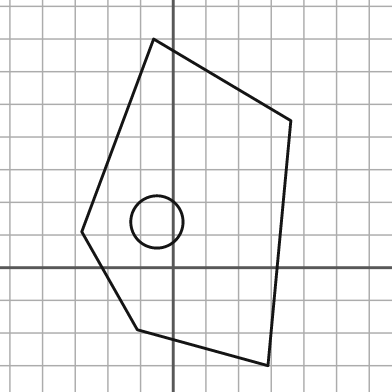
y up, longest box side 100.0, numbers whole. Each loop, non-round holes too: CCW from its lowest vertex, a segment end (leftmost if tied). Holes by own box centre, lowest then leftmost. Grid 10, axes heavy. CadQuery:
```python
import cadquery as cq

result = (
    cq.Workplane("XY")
    .moveTo(29.0, -30.0)
    .lineTo(36.0, 45.0)
    .lineTo(-6.0, 70.0)
    .lineTo(-28.0, 11.0)
    .lineTo(-11.0, -19.0)
    .close()
    .moveTo(-5.0, 14.0)
    .circle(8.0)
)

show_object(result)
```